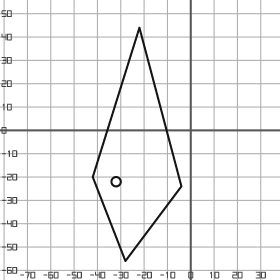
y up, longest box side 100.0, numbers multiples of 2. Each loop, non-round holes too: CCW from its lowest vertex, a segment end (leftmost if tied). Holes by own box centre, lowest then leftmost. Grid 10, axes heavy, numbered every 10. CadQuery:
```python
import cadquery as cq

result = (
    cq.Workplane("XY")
    .moveTo(-28.0, -56.0)
    .lineTo(-4.0, -24.0)
    .lineTo(-22.0, 44.0)
    .lineTo(-42.0, -20.0)
    .close()
    .moveTo(-32.0, -22.0)
    .circle(2.0)
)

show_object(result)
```